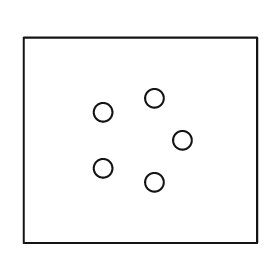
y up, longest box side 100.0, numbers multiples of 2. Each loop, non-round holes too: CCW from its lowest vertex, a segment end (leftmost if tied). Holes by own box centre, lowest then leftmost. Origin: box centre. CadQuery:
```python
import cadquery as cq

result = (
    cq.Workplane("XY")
    .moveTo(-50.0, -44.0)
    .lineTo(50.0, -44.0)
    .lineTo(50.0, 44.0)
    .lineTo(-50.0, 44.0)
    .close()
    .moveTo(6.0, -18.0)
    .circle(4.0)
    .moveTo(-16.0, -12.0)
    .circle(4.0)
    .moveTo(18.0, 0.0)
    .circle(4.0)
    .moveTo(-16.0, 12.0)
    .circle(4.0)
    .moveTo(6.0, 18.0)
    .circle(4.0)
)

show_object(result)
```